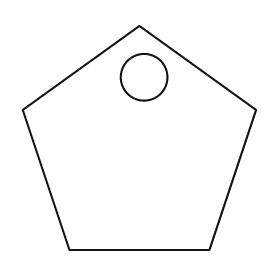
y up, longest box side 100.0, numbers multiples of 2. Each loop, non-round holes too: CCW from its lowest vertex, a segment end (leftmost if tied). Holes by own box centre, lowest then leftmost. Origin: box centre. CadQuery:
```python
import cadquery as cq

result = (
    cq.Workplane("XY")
    .moveTo(-30.0, -48.0)
    .lineTo(30.0, -48.0)
    .lineTo(50.0, 12.0)
    .lineTo(0.0, 48.0)
    .lineTo(-50.0, 12.0)
    .close()
    .moveTo(2.0, 26.0)
    .circle(10.0)
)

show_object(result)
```